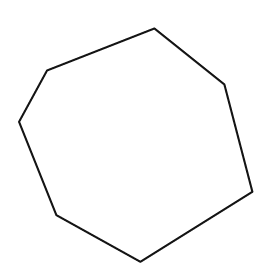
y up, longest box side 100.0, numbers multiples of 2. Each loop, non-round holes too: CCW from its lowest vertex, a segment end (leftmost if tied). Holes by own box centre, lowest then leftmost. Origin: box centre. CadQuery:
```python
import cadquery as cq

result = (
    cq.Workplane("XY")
    .moveTo(2.0, -50.0)
    .lineTo(50.0, -20.0)
    .lineTo(38.0, 26.0)
    .lineTo(8.0, 50.0)
    .lineTo(-38.0, 32.0)
    .lineTo(-50.0, 10.0)
    .lineTo(-34.0, -30.0)
    .close()
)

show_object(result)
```